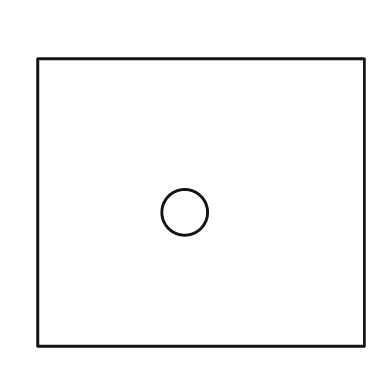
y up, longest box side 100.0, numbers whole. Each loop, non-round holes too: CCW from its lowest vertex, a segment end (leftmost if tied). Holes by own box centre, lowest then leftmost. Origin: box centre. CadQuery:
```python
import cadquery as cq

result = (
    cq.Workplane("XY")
    .moveTo(-50.0, -44.0)
    .lineTo(50.0, -44.0)
    .lineTo(50.0, 44.0)
    .lineTo(-50.0, 44.0)
    .close()
    .moveTo(-5.0, -3.0)
    .circle(7.0)
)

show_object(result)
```